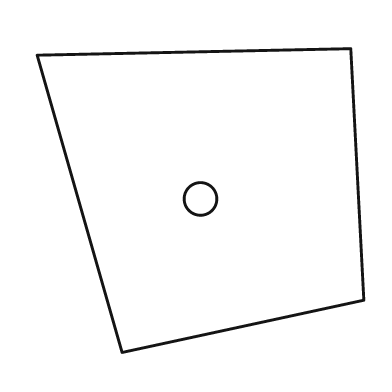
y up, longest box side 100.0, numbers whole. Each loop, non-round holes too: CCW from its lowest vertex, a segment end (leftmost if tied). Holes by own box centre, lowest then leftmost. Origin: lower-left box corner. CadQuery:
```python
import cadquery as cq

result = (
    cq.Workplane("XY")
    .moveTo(26.0, 0.0)
    .lineTo(100.0, 16.0)
    .lineTo(96.0, 93.0)
    .lineTo(0.0, 91.0)
    .close()
    .moveTo(50.0, 47.0)
    .circle(5.0)
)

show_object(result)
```